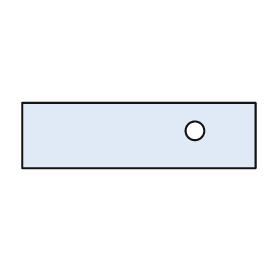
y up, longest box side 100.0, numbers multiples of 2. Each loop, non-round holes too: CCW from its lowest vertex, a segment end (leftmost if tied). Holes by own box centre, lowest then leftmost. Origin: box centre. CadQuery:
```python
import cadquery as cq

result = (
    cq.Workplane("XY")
    .moveTo(-50.0, -14.0)
    .lineTo(50.0, -14.0)
    .lineTo(50.0, 14.0)
    .lineTo(-50.0, 14.0)
    .close()
    .moveTo(24.0, 2.0)
    .circle(4.0)
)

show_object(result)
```